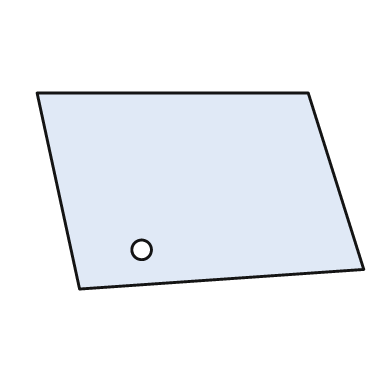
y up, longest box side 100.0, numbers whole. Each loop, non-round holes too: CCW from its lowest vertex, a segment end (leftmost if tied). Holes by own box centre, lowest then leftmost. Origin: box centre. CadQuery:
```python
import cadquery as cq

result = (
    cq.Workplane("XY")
    .moveTo(-37.0, -30.0)
    .lineTo(50.0, -24.0)
    .lineTo(33.0, 30.0)
    .lineTo(-50.0, 30.0)
    .close()
    .moveTo(-18.0, -18.0)
    .circle(3.0)
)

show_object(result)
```